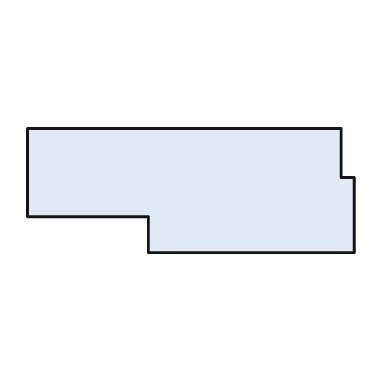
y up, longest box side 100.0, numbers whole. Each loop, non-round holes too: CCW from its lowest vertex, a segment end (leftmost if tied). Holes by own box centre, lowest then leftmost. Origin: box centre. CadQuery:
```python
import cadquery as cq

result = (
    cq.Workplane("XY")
    .moveTo(-13.0, -19.0)
    .lineTo(50.0, -19.0)
    .lineTo(50.0, 4.0)
    .lineTo(46.0, 4.0)
    .lineTo(46.0, 19.0)
    .lineTo(-50.0, 19.0)
    .lineTo(-50.0, -8.0)
    .lineTo(-13.0, -8.0)
    .close()
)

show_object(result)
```